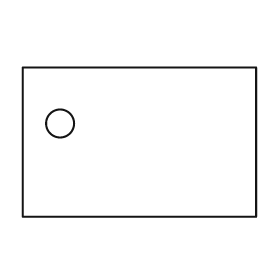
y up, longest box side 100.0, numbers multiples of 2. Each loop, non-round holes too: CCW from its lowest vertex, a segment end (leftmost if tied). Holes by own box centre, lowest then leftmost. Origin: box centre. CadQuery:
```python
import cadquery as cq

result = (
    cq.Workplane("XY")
    .moveTo(-50.0, -32.0)
    .lineTo(50.0, -32.0)
    .lineTo(50.0, 32.0)
    .lineTo(-50.0, 32.0)
    .close()
    .moveTo(-34.0, 8.0)
    .circle(6.0)
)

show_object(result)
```